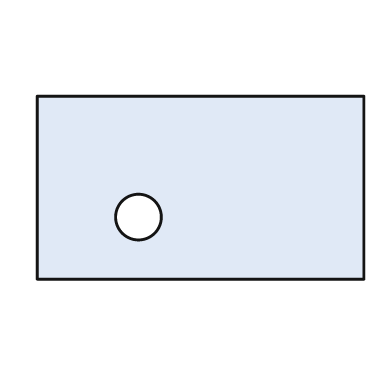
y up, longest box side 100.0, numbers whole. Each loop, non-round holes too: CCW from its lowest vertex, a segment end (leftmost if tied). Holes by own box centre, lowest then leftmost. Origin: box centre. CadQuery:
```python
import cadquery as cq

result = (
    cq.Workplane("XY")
    .moveTo(-50.0, -28.0)
    .lineTo(50.0, -28.0)
    .lineTo(50.0, 28.0)
    .lineTo(-50.0, 28.0)
    .close()
    .moveTo(-19.0, -9.0)
    .circle(7.0)
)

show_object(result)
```